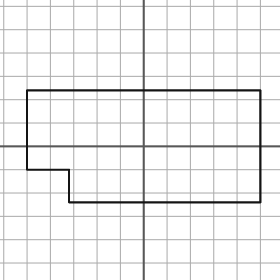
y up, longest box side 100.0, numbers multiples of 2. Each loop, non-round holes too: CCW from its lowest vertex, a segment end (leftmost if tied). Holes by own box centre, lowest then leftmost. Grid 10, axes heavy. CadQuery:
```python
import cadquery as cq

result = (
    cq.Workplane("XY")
    .moveTo(-32.0, -24.0)
    .lineTo(50.0, -24.0)
    .lineTo(50.0, 24.0)
    .lineTo(-50.0, 24.0)
    .lineTo(-50.0, -10.0)
    .lineTo(-32.0, -10.0)
    .close()
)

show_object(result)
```